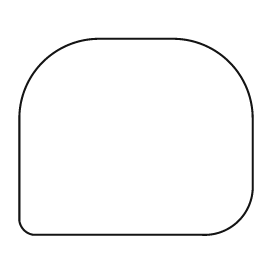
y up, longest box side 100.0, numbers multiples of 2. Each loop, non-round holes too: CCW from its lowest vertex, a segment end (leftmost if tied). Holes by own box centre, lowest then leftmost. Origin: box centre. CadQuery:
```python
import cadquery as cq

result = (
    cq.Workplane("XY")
    .moveTo(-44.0, -42.0)
    .lineTo(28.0, -42.0)
    .threePointArc((44.0, -36.0), (50.0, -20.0))
    .lineTo(50.0, 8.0)
    .threePointArc((40.0, 32.0), (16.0, 42.0))
    .lineTo(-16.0, 42.0)
    .threePointArc((-40.0, 32.0), (-50.0, 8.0))
    .lineTo(-50.0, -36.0)
    .threePointArc((-48.0, -40.0), (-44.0, -42.0))
    .close()
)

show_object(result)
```